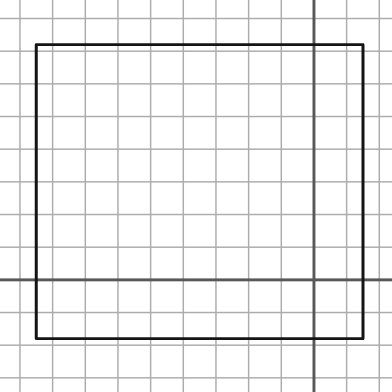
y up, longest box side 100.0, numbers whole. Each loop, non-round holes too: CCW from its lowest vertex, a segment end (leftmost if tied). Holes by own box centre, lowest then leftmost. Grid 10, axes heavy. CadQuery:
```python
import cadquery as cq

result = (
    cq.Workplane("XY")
    .moveTo(-85.0, -18.0)
    .lineTo(15.0, -18.0)
    .lineTo(15.0, 72.0)
    .lineTo(-85.0, 72.0)
    .close()
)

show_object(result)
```